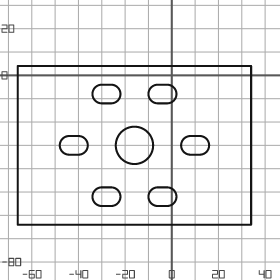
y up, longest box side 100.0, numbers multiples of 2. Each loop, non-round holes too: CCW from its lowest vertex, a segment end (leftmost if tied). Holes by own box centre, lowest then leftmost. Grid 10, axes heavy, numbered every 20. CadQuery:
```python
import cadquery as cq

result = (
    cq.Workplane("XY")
    .moveTo(-66.0, -64.0)
    .lineTo(34.0, -64.0)
    .lineTo(34.0, 4.0)
    .lineTo(-66.0, 4.0)
    .close()
    .moveTo(-30.0, -56.0)
    .lineTo(-26.0, -56.0)
    .threePointArc((-22.0, -52.0), (-26.0, -48.0))
    .lineTo(-30.0, -48.0)
    .threePointArc((-34.0, -52.0), (-30.0, -56.0))
    .close()
    .moveTo(-6.0, -56.0)
    .lineTo(-2.0, -56.0)
    .threePointArc((2.0, -52.0), (-2.0, -48.0))
    .lineTo(-6.0, -48.0)
    .threePointArc((-10.0, -52.0), (-6.0, -56.0))
    .close()
    .moveTo(-44.0, -34.0)
    .lineTo(-40.0, -34.0)
    .threePointArc((-36.0, -30.0), (-40.0, -26.0))
    .lineTo(-44.0, -26.0)
    .threePointArc((-48.0, -30.0), (-44.0, -34.0))
    .close()
    .moveTo(-16.0, -30.0)
    .circle(8.0)
    .moveTo(8.0, -34.0)
    .lineTo(12.0, -34.0)
    .threePointArc((16.0, -30.0), (12.0, -26.0))
    .lineTo(8.0, -26.0)
    .threePointArc((4.0, -30.0), (8.0, -34.0))
    .close()
    .moveTo(-30.0, -12.0)
    .lineTo(-26.0, -12.0)
    .threePointArc((-22.0, -8.0), (-26.0, -4.0))
    .lineTo(-30.0, -4.0)
    .threePointArc((-34.0, -8.0), (-30.0, -12.0))
    .close()
    .moveTo(-6.0, -12.0)
    .lineTo(-2.0, -12.0)
    .threePointArc((2.0, -8.0), (-2.0, -4.0))
    .lineTo(-6.0, -4.0)
    .threePointArc((-10.0, -8.0), (-6.0, -12.0))
    .close()
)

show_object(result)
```